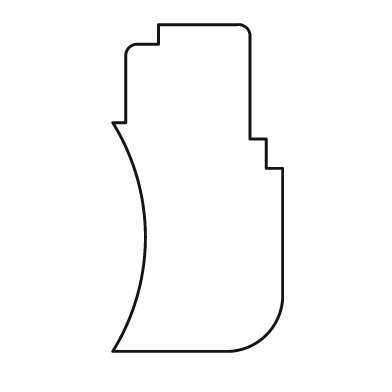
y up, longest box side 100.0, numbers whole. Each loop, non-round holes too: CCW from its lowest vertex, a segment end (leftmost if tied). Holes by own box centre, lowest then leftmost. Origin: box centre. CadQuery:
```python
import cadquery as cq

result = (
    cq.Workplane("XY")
    .moveTo(-26.0, -50.0)
    .lineTo(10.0, -50.0)
    .threePointArc((21.0, -45.0), (26.0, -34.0))
    .lineTo(26.0, 6.0)
    .lineTo(21.0, 6.0)
    .lineTo(21.0, 15.0)
    .lineTo(16.0, 15.0)
    .lineTo(16.0, 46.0)
    .threePointArc((15.0, 49.0), (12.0, 50.0))
    .lineTo(-12.0, 50.0)
    .lineTo(-12.0, 44.0)
    .lineTo(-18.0, 44.0)
    .threePointArc((-21.0, 43.0), (-22.0, 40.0))
    .lineTo(-22.0, 20.0)
    .lineTo(-26.0, 20.0)
    .threePointArc((-16.0, -15.0), (-26.0, -50.0))
    .close()
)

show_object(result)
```